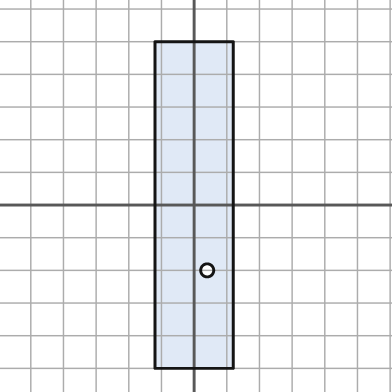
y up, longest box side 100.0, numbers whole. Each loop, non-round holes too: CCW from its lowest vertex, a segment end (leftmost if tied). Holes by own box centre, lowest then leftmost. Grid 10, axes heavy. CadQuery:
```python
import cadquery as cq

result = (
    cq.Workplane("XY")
    .moveTo(-12.0, -50.0)
    .lineTo(12.0, -50.0)
    .lineTo(12.0, 50.0)
    .lineTo(-12.0, 50.0)
    .close()
    .moveTo(4.0, -20.0)
    .circle(2.0)
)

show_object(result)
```